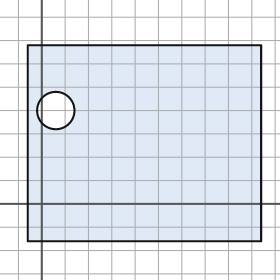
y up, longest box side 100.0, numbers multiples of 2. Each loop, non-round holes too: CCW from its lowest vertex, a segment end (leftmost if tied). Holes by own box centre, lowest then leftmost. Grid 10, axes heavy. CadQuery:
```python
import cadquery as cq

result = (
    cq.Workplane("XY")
    .moveTo(-6.0, -16.0)
    .lineTo(94.0, -16.0)
    .lineTo(94.0, 68.0)
    .lineTo(-6.0, 68.0)
    .close()
    .moveTo(6.0, 40.0)
    .circle(8.0)
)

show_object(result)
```